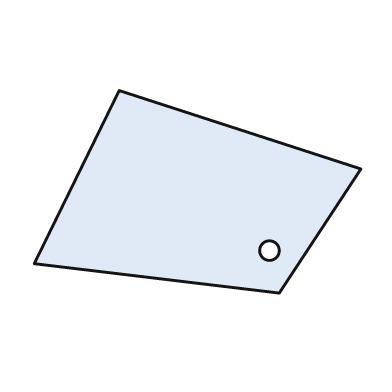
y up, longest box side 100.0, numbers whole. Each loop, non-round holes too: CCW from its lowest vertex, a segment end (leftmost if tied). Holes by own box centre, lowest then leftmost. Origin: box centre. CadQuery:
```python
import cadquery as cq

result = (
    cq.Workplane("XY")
    .moveTo(25.0, -31.0)
    .lineTo(50.0, 7.0)
    .lineTo(-24.0, 31.0)
    .lineTo(-50.0, -22.0)
    .close()
    .moveTo(22.0, -18.0)
    .circle(3.0)
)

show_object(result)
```